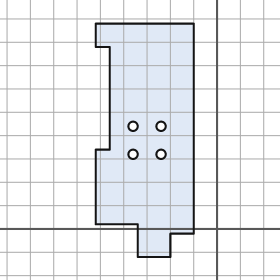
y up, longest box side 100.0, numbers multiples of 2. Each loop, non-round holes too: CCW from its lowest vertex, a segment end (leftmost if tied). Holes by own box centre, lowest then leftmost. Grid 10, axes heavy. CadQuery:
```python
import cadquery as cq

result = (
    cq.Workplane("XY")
    .moveTo(-34.0, -12.0)
    .lineTo(-20.0, -12.0)
    .lineTo(-20.0, -2.0)
    .lineTo(-10.0, -2.0)
    .lineTo(-10.0, 88.0)
    .lineTo(-52.0, 88.0)
    .lineTo(-52.0, 78.0)
    .lineTo(-46.0, 78.0)
    .lineTo(-46.0, 34.0)
    .lineTo(-52.0, 34.0)
    .lineTo(-52.0, 2.0)
    .lineTo(-34.0, 2.0)
    .close()
    .moveTo(-36.0, 32.0)
    .circle(2.0)
    .moveTo(-24.0, 32.0)
    .circle(2.0)
    .moveTo(-36.0, 44.0)
    .circle(2.0)
    .moveTo(-24.0, 44.0)
    .circle(2.0)
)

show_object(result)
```